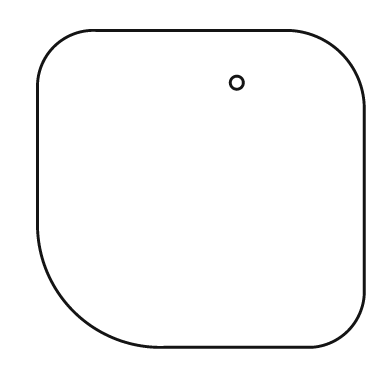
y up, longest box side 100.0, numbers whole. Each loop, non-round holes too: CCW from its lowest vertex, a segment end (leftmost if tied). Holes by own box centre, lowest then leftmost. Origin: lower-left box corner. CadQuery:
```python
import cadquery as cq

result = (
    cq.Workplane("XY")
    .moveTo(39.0, 0.0)
    .lineTo(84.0, 0.0)
    .threePointArc((95.0, 5.0), (100.0, 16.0))
    .lineTo(100.0, 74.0)
    .threePointArc((93.0, 90.0), (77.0, 97.0))
    .lineTo(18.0, 97.0)
    .threePointArc((5.0, 92.0), (0.0, 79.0))
    .lineTo(0.0, 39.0)
    .threePointArc((11.0, 11.0), (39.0, 0.0))
    .close()
    .moveTo(61.0, 81.0)
    .circle(2.0)
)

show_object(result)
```